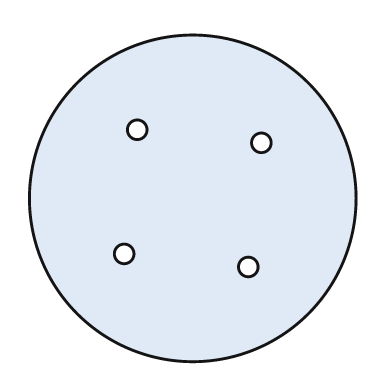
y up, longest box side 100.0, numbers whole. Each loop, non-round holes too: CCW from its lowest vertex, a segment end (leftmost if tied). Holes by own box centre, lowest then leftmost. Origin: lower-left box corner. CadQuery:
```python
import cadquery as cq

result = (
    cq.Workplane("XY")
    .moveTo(50.0, 50.0)
    .circle(50.0)
    .moveTo(67.0, 29.0)
    .circle(3.0)
    .moveTo(29.0, 33.0)
    .circle(3.0)
    .moveTo(71.0, 67.0)
    .circle(3.0)
    .moveTo(33.0, 71.0)
    .circle(3.0)
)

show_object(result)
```